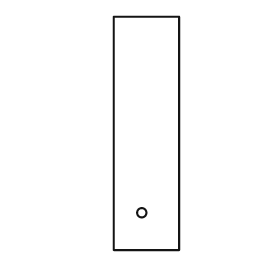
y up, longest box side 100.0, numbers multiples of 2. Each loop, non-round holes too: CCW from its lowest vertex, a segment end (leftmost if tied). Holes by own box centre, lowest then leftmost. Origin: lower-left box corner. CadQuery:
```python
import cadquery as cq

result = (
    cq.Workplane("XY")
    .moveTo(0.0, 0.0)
    .lineTo(28.0, 0.0)
    .lineTo(28.0, 100.0)
    .lineTo(0.0, 100.0)
    .close()
    .moveTo(12.0, 16.0)
    .circle(2.0)
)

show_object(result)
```